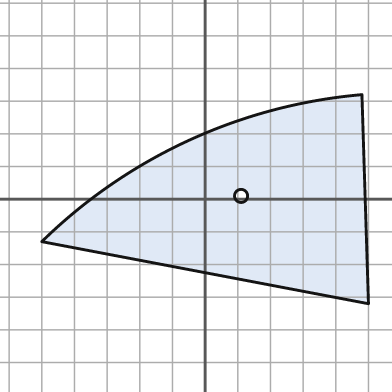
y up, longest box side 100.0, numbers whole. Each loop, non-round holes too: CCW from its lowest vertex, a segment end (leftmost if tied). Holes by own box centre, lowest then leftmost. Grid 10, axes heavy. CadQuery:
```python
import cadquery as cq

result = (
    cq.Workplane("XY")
    .moveTo(50.0, -32.0)
    .lineTo(48.0, 32.0)
    .threePointArc((-5.0, 18.0), (-50.0, -13.0))
    .close()
    .moveTo(11.0, 1.0)
    .circle(2.0)
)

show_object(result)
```